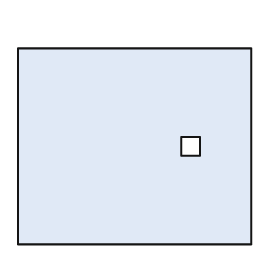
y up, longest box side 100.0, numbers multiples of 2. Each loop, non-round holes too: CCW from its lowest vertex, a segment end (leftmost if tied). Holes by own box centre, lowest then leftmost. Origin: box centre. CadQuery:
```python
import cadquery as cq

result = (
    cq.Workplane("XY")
    .moveTo(-50.0, -42.0)
    .lineTo(50.0, -42.0)
    .lineTo(50.0, 42.0)
    .lineTo(-50.0, 42.0)
    .close()
    .moveTo(20.0, -4.0)
    .lineTo(28.0, -4.0)
    .lineTo(28.0, 4.0)
    .lineTo(20.0, 4.0)
    .close()
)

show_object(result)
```